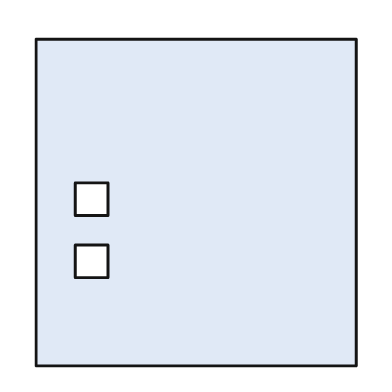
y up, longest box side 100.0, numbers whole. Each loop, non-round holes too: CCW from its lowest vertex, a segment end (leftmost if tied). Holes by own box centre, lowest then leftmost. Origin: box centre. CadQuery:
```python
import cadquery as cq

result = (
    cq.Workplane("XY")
    .moveTo(-49.0, -50.0)
    .lineTo(49.0, -50.0)
    .lineTo(49.0, 50.0)
    .lineTo(-49.0, 50.0)
    .close()
    .moveTo(-37.0, -23.0)
    .lineTo(-27.0, -23.0)
    .lineTo(-27.0, -13.0)
    .lineTo(-37.0, -13.0)
    .close()
    .moveTo(-37.0, -4.0)
    .lineTo(-27.0, -4.0)
    .lineTo(-27.0, 6.0)
    .lineTo(-37.0, 6.0)
    .close()
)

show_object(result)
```